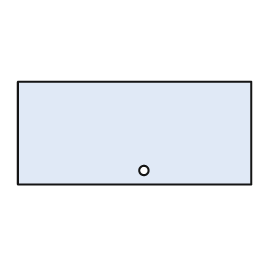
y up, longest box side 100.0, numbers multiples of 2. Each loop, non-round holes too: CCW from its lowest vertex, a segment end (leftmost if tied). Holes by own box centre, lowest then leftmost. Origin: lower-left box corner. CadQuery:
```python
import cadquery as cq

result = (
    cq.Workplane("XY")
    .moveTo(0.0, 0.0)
    .lineTo(100.0, 0.0)
    .lineTo(100.0, 44.0)
    .lineTo(0.0, 44.0)
    .close()
    .moveTo(54.0, 6.0)
    .circle(2.0)
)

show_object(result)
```